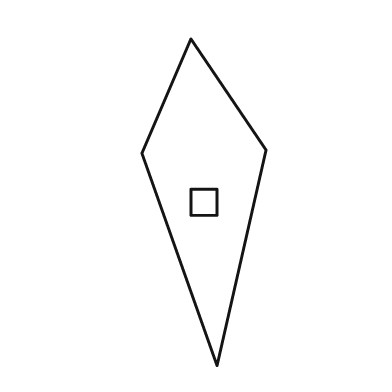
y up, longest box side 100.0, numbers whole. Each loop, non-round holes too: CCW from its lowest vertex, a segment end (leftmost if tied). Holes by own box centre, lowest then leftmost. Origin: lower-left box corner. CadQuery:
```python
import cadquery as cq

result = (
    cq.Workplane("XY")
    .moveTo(23.0, 0.0)
    .lineTo(38.0, 66.0)
    .lineTo(15.0, 100.0)
    .lineTo(0.0, 65.0)
    .close()
    .moveTo(15.0, 46.0)
    .lineTo(23.0, 46.0)
    .lineTo(23.0, 54.0)
    .lineTo(15.0, 54.0)
    .close()
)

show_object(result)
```